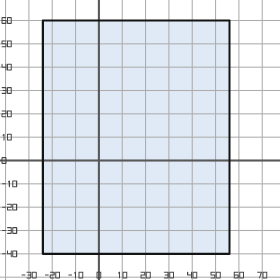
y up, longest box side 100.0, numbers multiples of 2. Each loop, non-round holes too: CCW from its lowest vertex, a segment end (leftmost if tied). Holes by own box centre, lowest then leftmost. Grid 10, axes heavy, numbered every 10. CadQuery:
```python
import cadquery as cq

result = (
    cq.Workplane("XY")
    .moveTo(-24.0, -40.0)
    .lineTo(56.0, -40.0)
    .lineTo(56.0, 60.0)
    .lineTo(-24.0, 60.0)
    .close()
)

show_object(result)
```